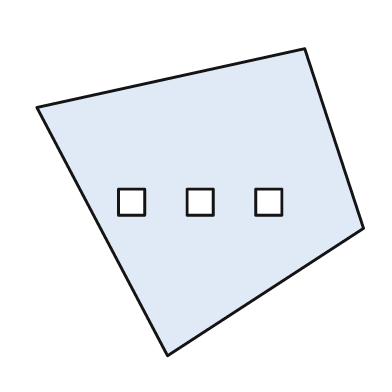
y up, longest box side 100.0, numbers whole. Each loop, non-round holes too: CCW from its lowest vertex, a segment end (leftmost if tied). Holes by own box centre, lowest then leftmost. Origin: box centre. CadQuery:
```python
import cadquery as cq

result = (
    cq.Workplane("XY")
    .moveTo(-10.0, -47.0)
    .lineTo(50.0, -8.0)
    .lineTo(32.0, 47.0)
    .lineTo(-50.0, 29.0)
    .close()
    .moveTo(-25.0, -4.0)
    .lineTo(-17.0, -4.0)
    .lineTo(-17.0, 4.0)
    .lineTo(-25.0, 4.0)
    .close()
    .moveTo(-4.0, -4.0)
    .lineTo(4.0, -4.0)
    .lineTo(4.0, 4.0)
    .lineTo(-4.0, 4.0)
    .close()
    .moveTo(17.0, -4.0)
    .lineTo(25.0, -4.0)
    .lineTo(25.0, 4.0)
    .lineTo(17.0, 4.0)
    .close()
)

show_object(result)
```